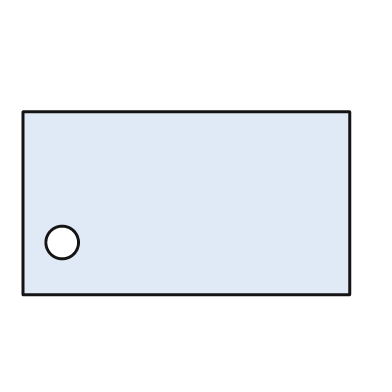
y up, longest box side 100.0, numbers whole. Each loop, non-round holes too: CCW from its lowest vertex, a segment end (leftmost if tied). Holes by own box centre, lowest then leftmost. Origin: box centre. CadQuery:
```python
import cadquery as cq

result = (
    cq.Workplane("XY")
    .moveTo(-50.0, -28.0)
    .lineTo(50.0, -28.0)
    .lineTo(50.0, 28.0)
    .lineTo(-50.0, 28.0)
    .close()
    .moveTo(-38.0, -12.0)
    .circle(5.0)
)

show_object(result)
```